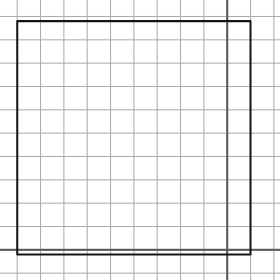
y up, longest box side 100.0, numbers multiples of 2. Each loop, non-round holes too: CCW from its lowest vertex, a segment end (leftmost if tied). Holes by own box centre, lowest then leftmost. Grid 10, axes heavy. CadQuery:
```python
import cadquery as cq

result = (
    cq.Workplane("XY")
    .moveTo(-90.0, -2.0)
    .lineTo(10.0, -2.0)
    .lineTo(10.0, 98.0)
    .lineTo(-90.0, 98.0)
    .close()
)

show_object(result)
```